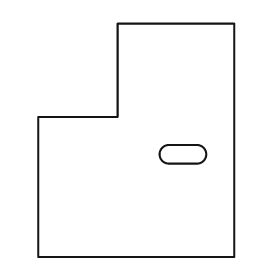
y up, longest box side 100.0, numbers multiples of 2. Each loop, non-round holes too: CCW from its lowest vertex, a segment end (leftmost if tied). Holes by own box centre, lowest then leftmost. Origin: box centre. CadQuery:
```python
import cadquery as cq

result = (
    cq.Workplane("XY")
    .moveTo(-42.0, -50.0)
    .lineTo(42.0, -50.0)
    .lineTo(42.0, 50.0)
    .lineTo(-8.0, 50.0)
    .lineTo(-8.0, 10.0)
    .lineTo(-42.0, 10.0)
    .close()
    .moveTo(14.0, -10.0)
    .lineTo(26.0, -10.0)
    .threePointArc((30.0, -6.0), (26.0, -2.0))
    .lineTo(14.0, -2.0)
    .threePointArc((10.0, -6.0), (14.0, -10.0))
    .close()
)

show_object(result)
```